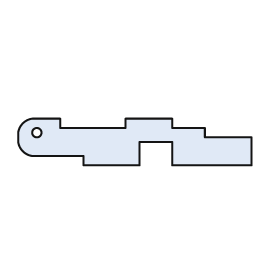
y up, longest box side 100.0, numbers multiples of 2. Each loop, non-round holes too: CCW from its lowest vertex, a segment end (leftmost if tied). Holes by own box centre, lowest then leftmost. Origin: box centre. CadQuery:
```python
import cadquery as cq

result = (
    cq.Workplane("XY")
    .moveTo(-22.0, -10.0)
    .lineTo(2.0, -10.0)
    .lineTo(2.0, 0.0)
    .lineTo(16.0, 0.0)
    .lineTo(16.0, -10.0)
    .lineTo(50.0, -10.0)
    .lineTo(50.0, 2.0)
    .lineTo(30.0, 2.0)
    .lineTo(30.0, 6.0)
    .lineTo(16.0, 6.0)
    .lineTo(16.0, 10.0)
    .lineTo(-4.0, 10.0)
    .lineTo(-4.0, 6.0)
    .lineTo(-32.0, 6.0)
    .lineTo(-32.0, 10.0)
    .lineTo(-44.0, 10.0)
    .threePointArc((-48.0, 8.0), (-50.0, 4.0))
    .lineTo(-50.0, 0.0)
    .threePointArc((-48.0, -4.0), (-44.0, -6.0))
    .lineTo(-22.0, -6.0)
    .close()
    .moveTo(-42.0, 4.0)
    .circle(2.0)
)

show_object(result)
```